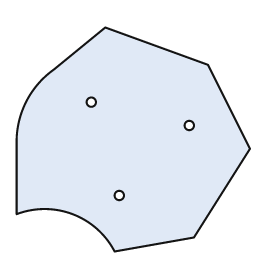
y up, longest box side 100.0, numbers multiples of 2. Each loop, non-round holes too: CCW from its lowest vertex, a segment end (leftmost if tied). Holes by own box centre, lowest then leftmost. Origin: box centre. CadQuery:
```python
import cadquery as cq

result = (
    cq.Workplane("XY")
    .moveTo(-8.0, -48.0)
    .lineTo(26.0, -42.0)
    .lineTo(50.0, -4.0)
    .lineTo(32.0, 32.0)
    .lineTo(-12.0, 48.0)
    .lineTo(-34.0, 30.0)
    .threePointArc((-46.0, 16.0), (-50.0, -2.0))
    .lineTo(-50.0, -32.0)
    .threePointArc((-26.0, -32.0), (-8.0, -48.0))
    .close()
    .moveTo(-6.0, -24.0)
    .circle(2.0)
    .moveTo(24.0, 6.0)
    .circle(2.0)
    .moveTo(-18.0, 16.0)
    .circle(2.0)
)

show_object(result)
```